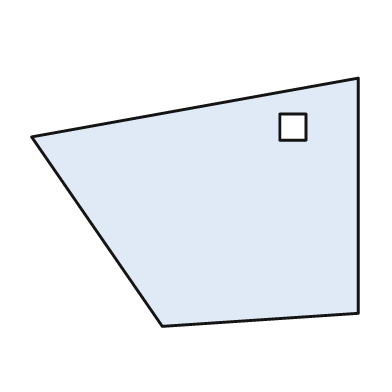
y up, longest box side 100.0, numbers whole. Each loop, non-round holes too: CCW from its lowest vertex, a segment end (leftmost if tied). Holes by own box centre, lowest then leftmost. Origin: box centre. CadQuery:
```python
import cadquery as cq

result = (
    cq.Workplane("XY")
    .moveTo(-10.0, -38.0)
    .lineTo(50.0, -34.0)
    .lineTo(50.0, 38.0)
    .lineTo(-50.0, 20.0)
    .close()
    .moveTo(26.0, 19.0)
    .lineTo(34.0, 19.0)
    .lineTo(34.0, 27.0)
    .lineTo(26.0, 27.0)
    .close()
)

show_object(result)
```